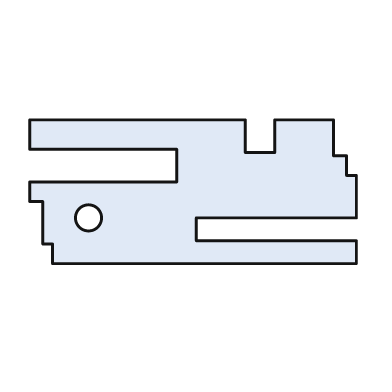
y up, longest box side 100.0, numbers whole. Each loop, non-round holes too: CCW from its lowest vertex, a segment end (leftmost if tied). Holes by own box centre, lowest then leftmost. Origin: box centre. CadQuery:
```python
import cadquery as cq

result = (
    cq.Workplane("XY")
    .moveTo(-43.0, -22.0)
    .lineTo(50.0, -22.0)
    .lineTo(50.0, -15.0)
    .lineTo(1.0, -15.0)
    .lineTo(1.0, -8.0)
    .lineTo(50.0, -8.0)
    .lineTo(50.0, 5.0)
    .lineTo(47.0, 5.0)
    .lineTo(47.0, 11.0)
    .lineTo(43.0, 11.0)
    .lineTo(43.0, 22.0)
    .lineTo(25.0, 22.0)
    .lineTo(25.0, 12.0)
    .lineTo(16.0, 12.0)
    .lineTo(16.0, 22.0)
    .lineTo(-50.0, 22.0)
    .lineTo(-50.0, 13.0)
    .lineTo(-5.0, 13.0)
    .lineTo(-5.0, 3.0)
    .lineTo(-50.0, 3.0)
    .lineTo(-50.0, -3.0)
    .lineTo(-46.0, -3.0)
    .lineTo(-46.0, -16.0)
    .lineTo(-43.0, -16.0)
    .close()
    .moveTo(-32.0, -8.0)
    .circle(4.0)
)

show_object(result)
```